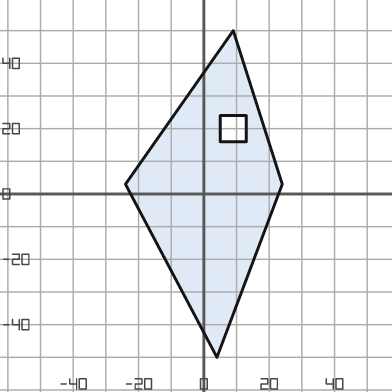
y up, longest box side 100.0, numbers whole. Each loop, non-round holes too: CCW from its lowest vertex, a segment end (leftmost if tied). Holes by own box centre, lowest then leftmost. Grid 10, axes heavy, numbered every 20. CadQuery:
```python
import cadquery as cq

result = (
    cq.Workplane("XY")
    .moveTo(4.0, -50.0)
    .lineTo(24.0, 3.0)
    .lineTo(9.0, 50.0)
    .lineTo(-24.0, 3.0)
    .close()
    .moveTo(5.0, 16.0)
    .lineTo(13.0, 16.0)
    .lineTo(13.0, 24.0)
    .lineTo(5.0, 24.0)
    .close()
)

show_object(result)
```